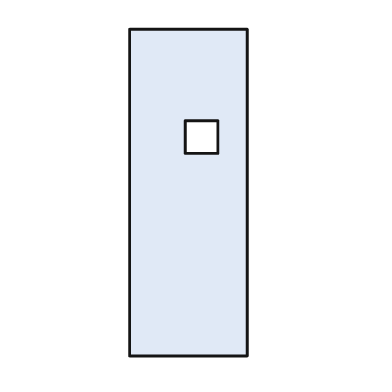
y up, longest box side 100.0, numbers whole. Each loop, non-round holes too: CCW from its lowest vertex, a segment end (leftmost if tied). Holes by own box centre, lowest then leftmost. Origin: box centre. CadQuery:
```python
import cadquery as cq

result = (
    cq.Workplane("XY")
    .moveTo(-18.0, -50.0)
    .lineTo(18.0, -50.0)
    .lineTo(18.0, 50.0)
    .lineTo(-18.0, 50.0)
    .close()
    .moveTo(-1.0, 12.0)
    .lineTo(9.0, 12.0)
    .lineTo(9.0, 22.0)
    .lineTo(-1.0, 22.0)
    .close()
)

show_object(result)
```